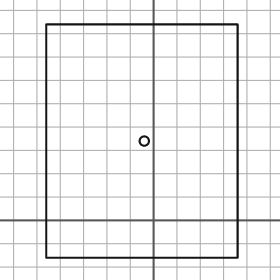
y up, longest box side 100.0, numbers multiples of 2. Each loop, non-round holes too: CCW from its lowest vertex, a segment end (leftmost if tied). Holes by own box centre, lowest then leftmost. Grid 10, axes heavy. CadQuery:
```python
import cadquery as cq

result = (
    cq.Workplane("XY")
    .moveTo(-46.0, -16.0)
    .lineTo(36.0, -16.0)
    .lineTo(36.0, 84.0)
    .lineTo(-46.0, 84.0)
    .close()
    .moveTo(-4.0, 34.0)
    .circle(2.0)
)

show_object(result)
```